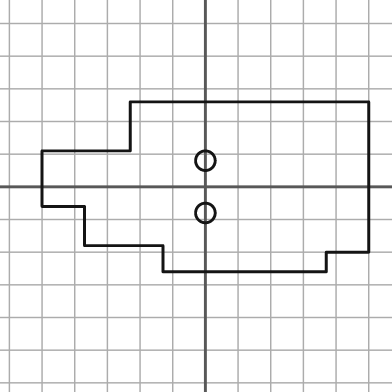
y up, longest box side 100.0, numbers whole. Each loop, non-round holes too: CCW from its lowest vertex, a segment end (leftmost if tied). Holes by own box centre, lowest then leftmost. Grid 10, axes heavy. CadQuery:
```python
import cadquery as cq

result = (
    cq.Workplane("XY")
    .moveTo(-13.0, -26.0)
    .lineTo(37.0, -26.0)
    .lineTo(37.0, -20.0)
    .lineTo(50.0, -20.0)
    .lineTo(50.0, 26.0)
    .lineTo(-23.0, 26.0)
    .lineTo(-23.0, 11.0)
    .lineTo(-50.0, 11.0)
    .lineTo(-50.0, -6.0)
    .lineTo(-37.0, -6.0)
    .lineTo(-37.0, -18.0)
    .lineTo(-13.0, -18.0)
    .close()
    .moveTo(0.0, -8.0)
    .circle(3.0)
    .moveTo(0.0, 8.0)
    .circle(3.0)
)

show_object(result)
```